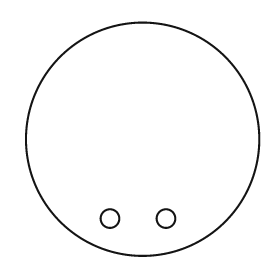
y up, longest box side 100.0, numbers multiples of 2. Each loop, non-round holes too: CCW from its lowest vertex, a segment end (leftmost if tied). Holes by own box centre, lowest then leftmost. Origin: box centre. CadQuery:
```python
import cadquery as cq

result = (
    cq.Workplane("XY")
    .moveTo(0.0, 0.0)
    .circle(50.0)
    .moveTo(-14.0, -34.0)
    .circle(4.0)
    .moveTo(10.0, -34.0)
    .circle(4.0)
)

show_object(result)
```